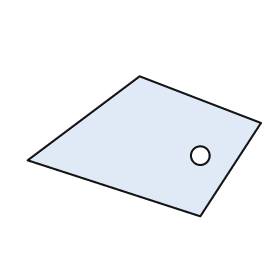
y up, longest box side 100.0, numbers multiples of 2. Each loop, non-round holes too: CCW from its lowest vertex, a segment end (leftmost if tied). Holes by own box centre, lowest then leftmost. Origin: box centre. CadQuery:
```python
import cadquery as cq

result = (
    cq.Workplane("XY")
    .moveTo(24.0, -30.0)
    .lineTo(50.0, 10.0)
    .lineTo(-2.0, 30.0)
    .lineTo(-50.0, -6.0)
    .close()
    .moveTo(24.0, -4.0)
    .circle(4.0)
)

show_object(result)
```